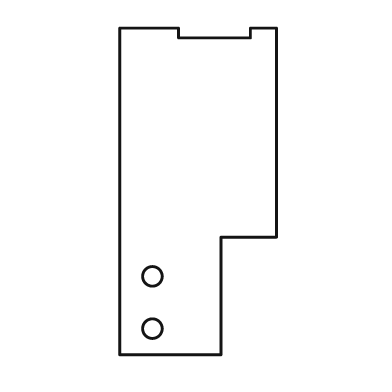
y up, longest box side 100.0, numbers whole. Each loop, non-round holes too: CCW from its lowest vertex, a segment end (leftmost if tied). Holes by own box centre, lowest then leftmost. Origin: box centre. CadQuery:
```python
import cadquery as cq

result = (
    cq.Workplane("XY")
    .moveTo(-24.0, -50.0)
    .lineTo(7.0, -50.0)
    .lineTo(7.0, -14.0)
    .lineTo(24.0, -14.0)
    .lineTo(24.0, 50.0)
    .lineTo(16.0, 50.0)
    .lineTo(16.0, 47.0)
    .lineTo(-6.0, 47.0)
    .lineTo(-6.0, 50.0)
    .lineTo(-24.0, 50.0)
    .close()
    .moveTo(-14.0, -42.0)
    .circle(3.0)
    .moveTo(-14.0, -26.0)
    .circle(3.0)
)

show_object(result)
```